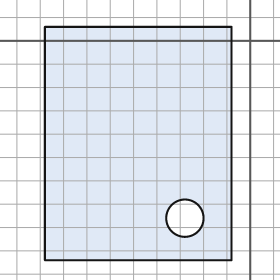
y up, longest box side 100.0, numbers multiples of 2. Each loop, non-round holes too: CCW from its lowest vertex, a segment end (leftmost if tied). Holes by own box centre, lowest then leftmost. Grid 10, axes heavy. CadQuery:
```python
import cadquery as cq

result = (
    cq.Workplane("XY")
    .moveTo(-88.0, -94.0)
    .lineTo(-8.0, -94.0)
    .lineTo(-8.0, 6.0)
    .lineTo(-88.0, 6.0)
    .close()
    .moveTo(-28.0, -76.0)
    .circle(8.0)
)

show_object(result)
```